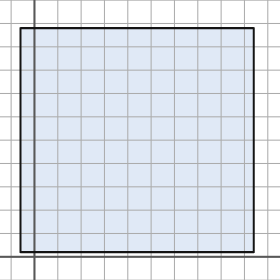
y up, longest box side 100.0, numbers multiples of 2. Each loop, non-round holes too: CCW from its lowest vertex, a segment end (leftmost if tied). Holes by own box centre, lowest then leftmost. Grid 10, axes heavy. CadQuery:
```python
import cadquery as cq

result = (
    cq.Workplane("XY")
    .moveTo(-6.0, 2.0)
    .lineTo(94.0, 2.0)
    .lineTo(94.0, 98.0)
    .lineTo(-6.0, 98.0)
    .close()
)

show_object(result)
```